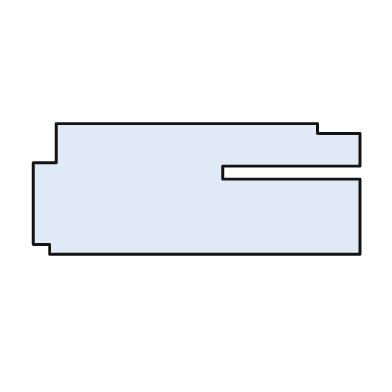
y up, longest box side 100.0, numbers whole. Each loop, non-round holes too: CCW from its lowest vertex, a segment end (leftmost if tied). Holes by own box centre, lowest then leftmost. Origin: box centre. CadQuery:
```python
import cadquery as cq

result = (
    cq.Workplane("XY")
    .moveTo(-45.0, -20.0)
    .lineTo(50.0, -20.0)
    .lineTo(50.0, 3.0)
    .lineTo(8.0, 3.0)
    .lineTo(8.0, 7.0)
    .lineTo(50.0, 7.0)
    .lineTo(50.0, 17.0)
    .lineTo(37.0, 17.0)
    .lineTo(37.0, 20.0)
    .lineTo(-43.0, 20.0)
    .lineTo(-43.0, 8.0)
    .lineTo(-50.0, 8.0)
    .lineTo(-50.0, -17.0)
    .lineTo(-45.0, -17.0)
    .close()
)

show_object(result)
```